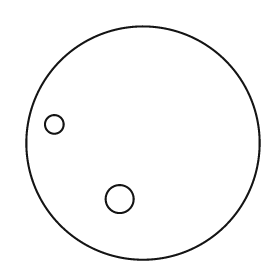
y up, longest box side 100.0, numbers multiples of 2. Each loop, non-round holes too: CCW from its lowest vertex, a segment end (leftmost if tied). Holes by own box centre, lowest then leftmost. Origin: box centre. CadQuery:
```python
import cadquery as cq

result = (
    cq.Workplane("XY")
    .moveTo(0.0, 0.0)
    .circle(50.0)
    .moveTo(-10.0, -24.0)
    .circle(6.0)
    .moveTo(-38.0, 8.0)
    .circle(4.0)
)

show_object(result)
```